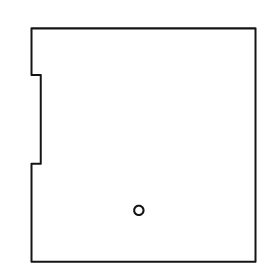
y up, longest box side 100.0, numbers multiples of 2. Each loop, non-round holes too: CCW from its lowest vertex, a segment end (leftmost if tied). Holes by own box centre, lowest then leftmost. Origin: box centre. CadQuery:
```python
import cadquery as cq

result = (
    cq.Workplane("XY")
    .moveTo(-48.0, -50.0)
    .lineTo(48.0, -50.0)
    .lineTo(48.0, 50.0)
    .lineTo(-48.0, 50.0)
    .lineTo(-48.0, 30.0)
    .lineTo(-44.0, 30.0)
    .lineTo(-44.0, -8.0)
    .lineTo(-48.0, -8.0)
    .close()
    .moveTo(-2.0, -28.0)
    .circle(2.0)
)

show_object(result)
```